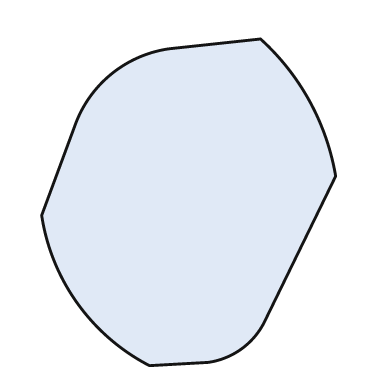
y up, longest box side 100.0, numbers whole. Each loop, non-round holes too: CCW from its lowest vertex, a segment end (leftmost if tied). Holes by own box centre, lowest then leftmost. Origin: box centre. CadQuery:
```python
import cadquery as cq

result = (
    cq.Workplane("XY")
    .moveTo(-12.0, -50.0)
    .lineTo(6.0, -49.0)
    .threePointArc((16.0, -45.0), (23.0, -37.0))
    .lineTo(45.0, 8.0)
    .threePointArc((37.0, 31.0), (22.0, 50.0))
    .lineTo(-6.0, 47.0)
    .threePointArc((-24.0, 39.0), (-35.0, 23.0))
    .lineTo(-45.0, -4.0)
    .threePointArc((-34.0, -31.0), (-12.0, -50.0))
    .close()
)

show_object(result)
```